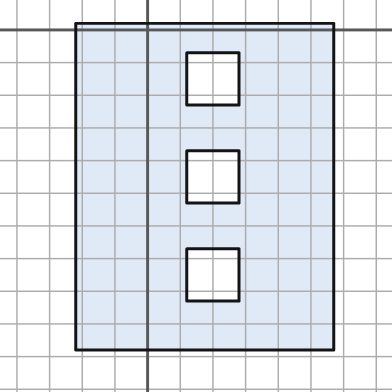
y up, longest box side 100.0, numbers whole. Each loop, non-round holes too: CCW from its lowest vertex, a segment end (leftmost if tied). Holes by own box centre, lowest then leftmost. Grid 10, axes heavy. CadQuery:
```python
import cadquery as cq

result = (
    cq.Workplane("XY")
    .moveTo(-22.0, -98.0)
    .lineTo(57.0, -98.0)
    .lineTo(57.0, 2.0)
    .lineTo(-22.0, 2.0)
    .close()
    .moveTo(12.0, -83.0)
    .lineTo(28.0, -83.0)
    .lineTo(28.0, -67.0)
    .lineTo(12.0, -67.0)
    .close()
    .moveTo(12.0, -53.0)
    .lineTo(28.0, -53.0)
    .lineTo(28.0, -37.0)
    .lineTo(12.0, -37.0)
    .close()
    .moveTo(12.0, -23.0)
    .lineTo(28.0, -23.0)
    .lineTo(28.0, -7.0)
    .lineTo(12.0, -7.0)
    .close()
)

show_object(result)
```